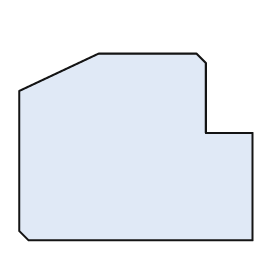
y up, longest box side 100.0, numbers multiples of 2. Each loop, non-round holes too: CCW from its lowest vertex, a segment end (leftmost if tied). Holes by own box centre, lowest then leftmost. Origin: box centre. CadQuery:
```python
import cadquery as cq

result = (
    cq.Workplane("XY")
    .moveTo(-46.0, -40.0)
    .lineTo(50.0, -40.0)
    .lineTo(50.0, 6.0)
    .lineTo(30.0, 6.0)
    .lineTo(30.0, 36.0)
    .lineTo(26.0, 40.0)
    .lineTo(-16.0, 40.0)
    .lineTo(-50.0, 24.0)
    .lineTo(-50.0, -36.0)
    .close()
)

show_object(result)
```